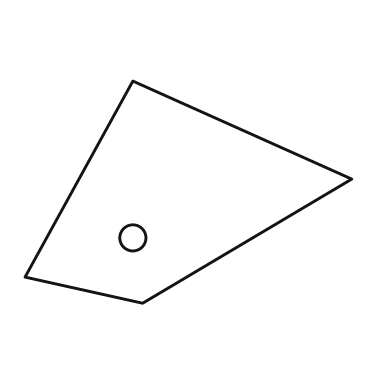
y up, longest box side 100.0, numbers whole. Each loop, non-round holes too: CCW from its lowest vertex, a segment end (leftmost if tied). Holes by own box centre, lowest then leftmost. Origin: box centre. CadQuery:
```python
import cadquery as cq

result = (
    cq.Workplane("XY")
    .moveTo(-14.0, -34.0)
    .lineTo(50.0, 4.0)
    .lineTo(-17.0, 34.0)
    .lineTo(-50.0, -26.0)
    .close()
    .moveTo(-17.0, -14.0)
    .circle(4.0)
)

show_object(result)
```